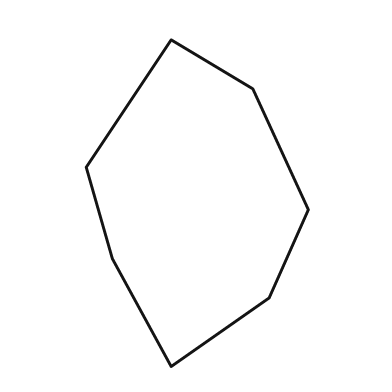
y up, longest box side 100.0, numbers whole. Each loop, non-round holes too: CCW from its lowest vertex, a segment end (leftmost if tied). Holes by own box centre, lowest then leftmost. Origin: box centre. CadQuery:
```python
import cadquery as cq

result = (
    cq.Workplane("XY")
    .moveTo(-8.0, -50.0)
    .lineTo(22.0, -29.0)
    .lineTo(34.0, -2.0)
    .lineTo(17.0, 35.0)
    .lineTo(-8.0, 50.0)
    .lineTo(-34.0, 11.0)
    .lineTo(-26.0, -17.0)
    .close()
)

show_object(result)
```